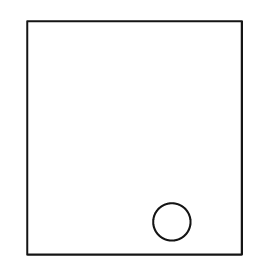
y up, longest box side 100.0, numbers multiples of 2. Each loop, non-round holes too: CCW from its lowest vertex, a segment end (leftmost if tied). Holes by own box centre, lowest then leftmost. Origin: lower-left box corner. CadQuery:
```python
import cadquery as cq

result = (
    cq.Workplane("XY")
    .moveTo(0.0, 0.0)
    .lineTo(92.0, 0.0)
    .lineTo(92.0, 100.0)
    .lineTo(0.0, 100.0)
    .close()
    .moveTo(62.0, 14.0)
    .circle(8.0)
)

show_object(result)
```